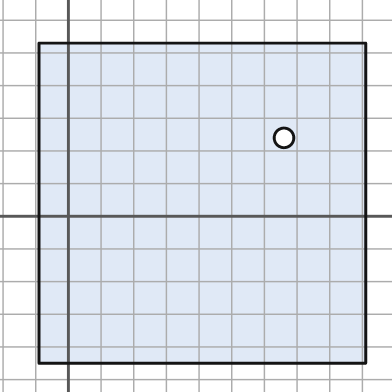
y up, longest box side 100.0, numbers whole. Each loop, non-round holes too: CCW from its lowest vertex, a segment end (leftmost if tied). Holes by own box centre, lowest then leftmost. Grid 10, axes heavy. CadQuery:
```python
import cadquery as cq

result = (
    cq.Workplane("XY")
    .moveTo(-9.0, -45.0)
    .lineTo(91.0, -45.0)
    .lineTo(91.0, 53.0)
    .lineTo(-9.0, 53.0)
    .close()
    .moveTo(66.0, 24.0)
    .circle(3.0)
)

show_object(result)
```